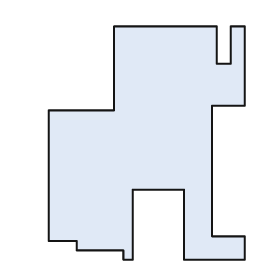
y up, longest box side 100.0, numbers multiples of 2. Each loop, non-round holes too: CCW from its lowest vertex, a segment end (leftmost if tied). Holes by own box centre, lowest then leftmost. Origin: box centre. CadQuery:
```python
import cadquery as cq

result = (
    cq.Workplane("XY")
    .moveTo(-10.0, -50.0)
    .lineTo(-6.0, -50.0)
    .lineTo(-6.0, -20.0)
    .lineTo(16.0, -20.0)
    .lineTo(16.0, -50.0)
    .lineTo(42.0, -50.0)
    .lineTo(42.0, -40.0)
    .lineTo(28.0, -40.0)
    .lineTo(28.0, 16.0)
    .lineTo(42.0, 16.0)
    .lineTo(42.0, 50.0)
    .lineTo(36.0, 50.0)
    .lineTo(36.0, 34.0)
    .lineTo(30.0, 34.0)
    .lineTo(30.0, 50.0)
    .lineTo(-14.0, 50.0)
    .lineTo(-14.0, 14.0)
    .lineTo(-42.0, 14.0)
    .lineTo(-42.0, -42.0)
    .lineTo(-30.0, -42.0)
    .lineTo(-30.0, -46.0)
    .lineTo(-10.0, -46.0)
    .close()
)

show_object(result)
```